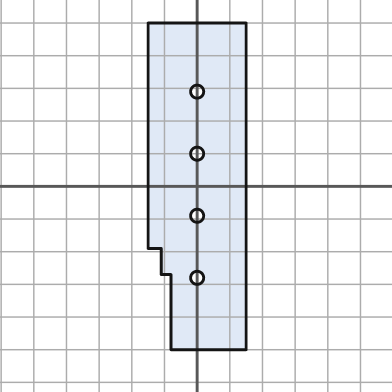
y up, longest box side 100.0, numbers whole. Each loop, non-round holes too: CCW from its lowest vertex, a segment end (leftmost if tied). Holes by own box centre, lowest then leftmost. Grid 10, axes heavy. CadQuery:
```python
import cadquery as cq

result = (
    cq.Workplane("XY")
    .moveTo(-8.0, -50.0)
    .lineTo(15.0, -50.0)
    .lineTo(15.0, 50.0)
    .lineTo(-15.0, 50.0)
    .lineTo(-15.0, -19.0)
    .lineTo(-11.0, -19.0)
    .lineTo(-11.0, -27.0)
    .lineTo(-8.0, -27.0)
    .close()
    .moveTo(0.0, -28.0)
    .circle(2.0)
    .moveTo(0.0, -9.0)
    .circle(2.0)
    .moveTo(0.0, 10.0)
    .circle(2.0)
    .moveTo(0.0, 29.0)
    .circle(2.0)
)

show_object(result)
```